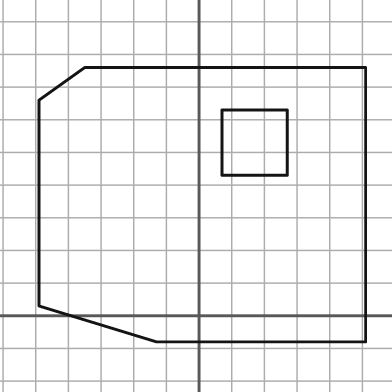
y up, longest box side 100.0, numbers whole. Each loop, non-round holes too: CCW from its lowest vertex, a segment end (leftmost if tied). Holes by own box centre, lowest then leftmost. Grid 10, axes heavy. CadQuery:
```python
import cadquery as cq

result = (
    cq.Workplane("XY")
    .moveTo(-13.0, -8.0)
    .lineTo(51.0, -8.0)
    .lineTo(51.0, 76.0)
    .lineTo(-35.0, 76.0)
    .lineTo(-49.0, 66.0)
    .lineTo(-49.0, 3.0)
    .close()
    .moveTo(7.0, 43.0)
    .lineTo(27.0, 43.0)
    .lineTo(27.0, 63.0)
    .lineTo(7.0, 63.0)
    .close()
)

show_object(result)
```